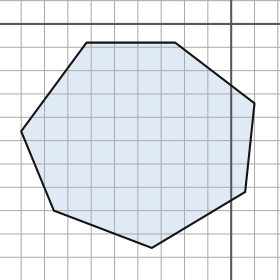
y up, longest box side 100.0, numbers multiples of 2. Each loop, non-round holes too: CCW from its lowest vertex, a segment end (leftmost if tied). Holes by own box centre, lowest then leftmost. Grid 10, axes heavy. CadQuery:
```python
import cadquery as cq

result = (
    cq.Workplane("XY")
    .moveTo(-34.0, -96.0)
    .lineTo(6.0, -72.0)
    .lineTo(10.0, -34.0)
    .lineTo(-24.0, -8.0)
    .lineTo(-62.0, -8.0)
    .lineTo(-90.0, -46.0)
    .lineTo(-76.0, -80.0)
    .close()
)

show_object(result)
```